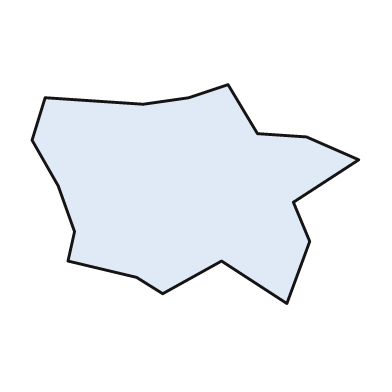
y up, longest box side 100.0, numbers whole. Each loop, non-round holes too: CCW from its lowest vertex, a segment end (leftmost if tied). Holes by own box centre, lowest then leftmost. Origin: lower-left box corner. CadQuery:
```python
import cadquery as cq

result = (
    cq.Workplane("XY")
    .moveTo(78.0, 0.0)
    .lineTo(85.0, 19.0)
    .lineTo(80.0, 31.0)
    .lineTo(100.0, 44.0)
    .lineTo(84.0, 51.0)
    .lineTo(69.0, 52.0)
    .lineTo(60.0, 67.0)
    .lineTo(48.0, 63.0)
    .lineTo(34.0, 61.0)
    .lineTo(4.0, 63.0)
    .lineTo(0.0, 50.0)
    .lineTo(8.0, 36.0)
    .lineTo(13.0, 22.0)
    .lineTo(11.0, 13.0)
    .lineTo(32.0, 8.0)
    .lineTo(40.0, 3.0)
    .lineTo(58.0, 13.0)
    .close()
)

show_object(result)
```